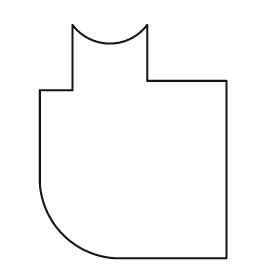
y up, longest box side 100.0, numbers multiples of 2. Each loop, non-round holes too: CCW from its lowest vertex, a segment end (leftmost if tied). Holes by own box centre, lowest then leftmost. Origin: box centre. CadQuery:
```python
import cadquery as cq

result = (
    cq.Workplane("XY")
    .moveTo(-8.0, -50.0)
    .lineTo(40.0, -50.0)
    .lineTo(40.0, 26.0)
    .lineTo(6.0, 26.0)
    .lineTo(6.0, 50.0)
    .threePointArc((-10.0, 42.0), (-26.0, 50.0))
    .lineTo(-26.0, 22.0)
    .lineTo(-40.0, 22.0)
    .lineTo(-40.0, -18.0)
    .threePointArc((-30.0, -40.0), (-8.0, -50.0))
    .close()
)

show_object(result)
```